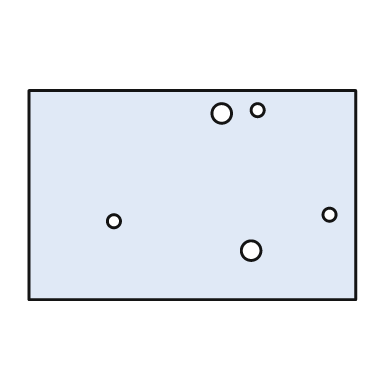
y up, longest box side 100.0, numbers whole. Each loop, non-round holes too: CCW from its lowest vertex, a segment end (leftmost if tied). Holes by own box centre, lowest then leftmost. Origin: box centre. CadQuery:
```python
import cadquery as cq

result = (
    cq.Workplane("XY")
    .moveTo(-50.0, -32.0)
    .lineTo(50.0, -32.0)
    .lineTo(50.0, 32.0)
    .lineTo(-50.0, 32.0)
    .close()
    .moveTo(18.0, -17.0)
    .circle(3.0)
    .moveTo(-24.0, -8.0)
    .circle(2.0)
    .moveTo(42.0, -6.0)
    .circle(2.0)
    .moveTo(9.0, 25.0)
    .circle(3.0)
    .moveTo(20.0, 26.0)
    .circle(2.0)
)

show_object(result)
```